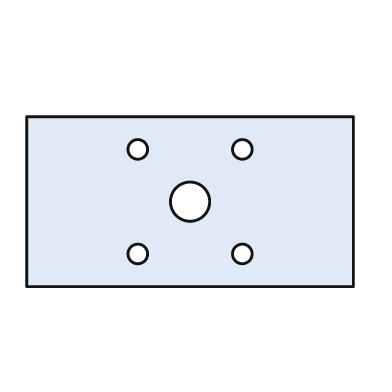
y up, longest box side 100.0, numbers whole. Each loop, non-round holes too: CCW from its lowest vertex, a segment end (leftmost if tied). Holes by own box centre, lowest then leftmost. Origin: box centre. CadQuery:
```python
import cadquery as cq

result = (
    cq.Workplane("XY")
    .moveTo(-50.0, -26.0)
    .lineTo(50.0, -26.0)
    .lineTo(50.0, 26.0)
    .lineTo(-50.0, 26.0)
    .close()
    .moveTo(-16.0, -16.0)
    .circle(3.0)
    .moveTo(16.0, -16.0)
    .circle(3.0)
    .moveTo(0.0, 0.0)
    .circle(6.0)
    .moveTo(-16.0, 16.0)
    .circle(3.0)
    .moveTo(16.0, 16.0)
    .circle(3.0)
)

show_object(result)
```